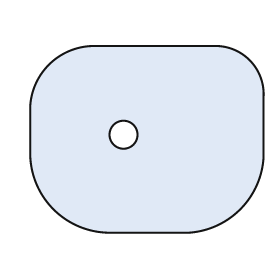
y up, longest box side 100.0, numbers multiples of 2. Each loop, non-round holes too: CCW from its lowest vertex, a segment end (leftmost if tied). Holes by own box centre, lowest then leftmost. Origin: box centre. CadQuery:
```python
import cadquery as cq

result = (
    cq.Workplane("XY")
    .moveTo(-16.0, -40.0)
    .lineTo(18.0, -40.0)
    .threePointArc((40.0, -30.0), (50.0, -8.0))
    .lineTo(50.0, 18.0)
    .threePointArc((44.0, 34.0), (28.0, 40.0))
    .lineTo(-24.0, 40.0)
    .threePointArc((-42.0, 32.0), (-50.0, 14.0))
    .lineTo(-50.0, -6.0)
    .threePointArc((-40.0, -30.0), (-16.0, -40.0))
    .close()
    .moveTo(-10.0, 2.0)
    .circle(6.0)
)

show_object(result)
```